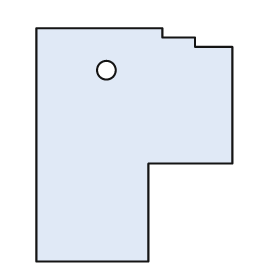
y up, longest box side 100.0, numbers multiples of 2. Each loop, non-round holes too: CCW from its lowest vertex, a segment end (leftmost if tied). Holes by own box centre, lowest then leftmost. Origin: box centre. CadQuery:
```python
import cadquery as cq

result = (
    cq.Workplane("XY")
    .moveTo(-42.0, -50.0)
    .lineTo(6.0, -50.0)
    .lineTo(6.0, -8.0)
    .lineTo(42.0, -8.0)
    .lineTo(42.0, 42.0)
    .lineTo(26.0, 42.0)
    .lineTo(26.0, 46.0)
    .lineTo(12.0, 46.0)
    .lineTo(12.0, 50.0)
    .lineTo(-42.0, 50.0)
    .close()
    .moveTo(-12.0, 32.0)
    .circle(4.0)
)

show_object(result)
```